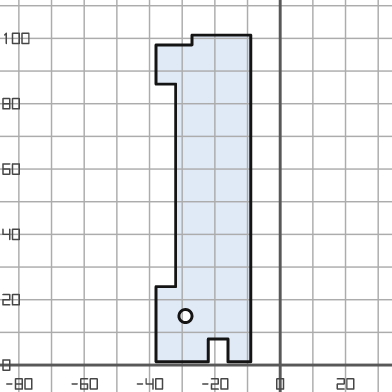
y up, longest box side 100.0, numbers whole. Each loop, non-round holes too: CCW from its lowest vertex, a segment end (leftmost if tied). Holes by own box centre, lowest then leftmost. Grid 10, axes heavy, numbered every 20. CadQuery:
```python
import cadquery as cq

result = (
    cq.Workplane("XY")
    .moveTo(-38.0, 1.0)
    .lineTo(-22.0, 1.0)
    .lineTo(-22.0, 8.0)
    .lineTo(-16.0, 8.0)
    .lineTo(-16.0, 1.0)
    .lineTo(-9.0, 1.0)
    .lineTo(-9.0, 101.0)
    .lineTo(-27.0, 101.0)
    .lineTo(-27.0, 98.0)
    .lineTo(-38.0, 98.0)
    .lineTo(-38.0, 86.0)
    .lineTo(-32.0, 86.0)
    .lineTo(-32.0, 24.0)
    .lineTo(-38.0, 24.0)
    .close()
    .moveTo(-29.0, 15.0)
    .circle(2.0)
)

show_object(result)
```